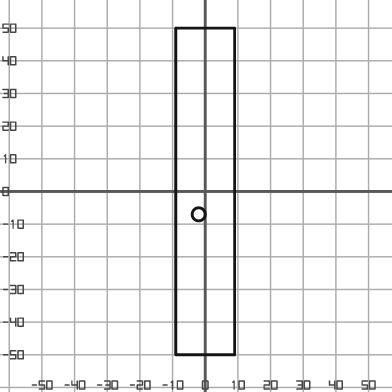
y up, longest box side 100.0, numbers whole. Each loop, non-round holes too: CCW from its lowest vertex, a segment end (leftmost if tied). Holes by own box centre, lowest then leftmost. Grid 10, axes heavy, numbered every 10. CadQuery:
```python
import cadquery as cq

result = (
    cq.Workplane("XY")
    .moveTo(-9.0, -50.0)
    .lineTo(9.0, -50.0)
    .lineTo(9.0, 50.0)
    .lineTo(-9.0, 50.0)
    .close()
    .moveTo(-2.0, -7.0)
    .circle(2.0)
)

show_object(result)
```